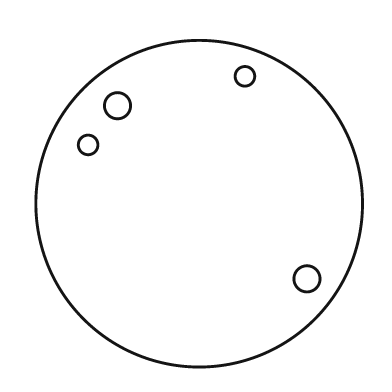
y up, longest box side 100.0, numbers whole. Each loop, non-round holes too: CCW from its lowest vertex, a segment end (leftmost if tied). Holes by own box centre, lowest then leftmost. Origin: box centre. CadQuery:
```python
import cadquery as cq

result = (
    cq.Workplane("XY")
    .moveTo(0.0, 0.0)
    .circle(50.0)
    .moveTo(33.0, -23.0)
    .circle(4.0)
    .moveTo(-34.0, 18.0)
    .circle(3.0)
    .moveTo(-25.0, 30.0)
    .circle(4.0)
    .moveTo(14.0, 39.0)
    .circle(3.0)
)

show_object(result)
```